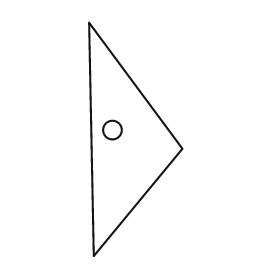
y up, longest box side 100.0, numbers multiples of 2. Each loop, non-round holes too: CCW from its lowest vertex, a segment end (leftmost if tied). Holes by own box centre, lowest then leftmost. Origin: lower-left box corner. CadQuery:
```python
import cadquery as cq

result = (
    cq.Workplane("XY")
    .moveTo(2.0, 0.0)
    .lineTo(40.0, 46.0)
    .lineTo(0.0, 100.0)
    .close()
    .moveTo(10.0, 54.0)
    .circle(4.0)
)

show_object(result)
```